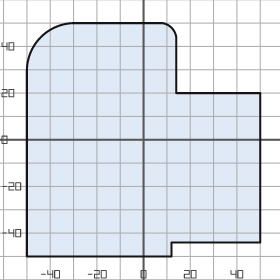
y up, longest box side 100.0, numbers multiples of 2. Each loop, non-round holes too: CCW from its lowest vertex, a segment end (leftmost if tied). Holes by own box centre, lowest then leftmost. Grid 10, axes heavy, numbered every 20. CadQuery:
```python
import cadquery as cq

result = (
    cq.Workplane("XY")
    .moveTo(-50.0, -50.0)
    .lineTo(12.0, -50.0)
    .lineTo(12.0, -44.0)
    .lineTo(50.0, -44.0)
    .lineTo(50.0, 20.0)
    .lineTo(14.0, 20.0)
    .lineTo(14.0, 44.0)
    .threePointArc((12.0, 48.0), (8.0, 50.0))
    .lineTo(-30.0, 50.0)
    .threePointArc((-44.0, 44.0), (-50.0, 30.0))
    .close()
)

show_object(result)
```